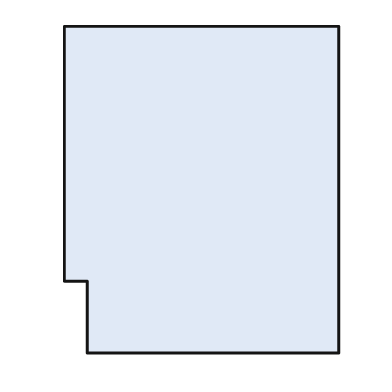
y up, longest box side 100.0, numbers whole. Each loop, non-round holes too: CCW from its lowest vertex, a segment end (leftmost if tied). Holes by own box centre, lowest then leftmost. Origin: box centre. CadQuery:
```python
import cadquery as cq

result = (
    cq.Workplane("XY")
    .moveTo(-35.0, -50.0)
    .lineTo(42.0, -50.0)
    .lineTo(42.0, 50.0)
    .lineTo(-42.0, 50.0)
    .lineTo(-42.0, -28.0)
    .lineTo(-35.0, -28.0)
    .close()
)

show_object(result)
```